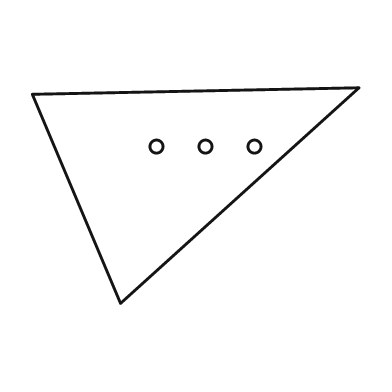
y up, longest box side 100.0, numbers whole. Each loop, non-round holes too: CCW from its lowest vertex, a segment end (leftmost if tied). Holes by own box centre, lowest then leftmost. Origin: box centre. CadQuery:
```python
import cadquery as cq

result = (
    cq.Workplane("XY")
    .moveTo(-23.0, -33.0)
    .lineTo(50.0, 33.0)
    .lineTo(-50.0, 31.0)
    .close()
    .moveTo(-12.0, 15.0)
    .circle(2.0)
    .moveTo(3.0, 15.0)
    .circle(2.0)
    .moveTo(18.0, 15.0)
    .circle(2.0)
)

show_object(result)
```